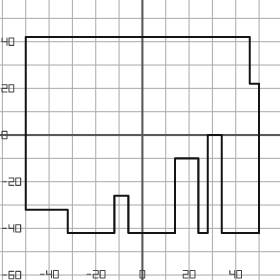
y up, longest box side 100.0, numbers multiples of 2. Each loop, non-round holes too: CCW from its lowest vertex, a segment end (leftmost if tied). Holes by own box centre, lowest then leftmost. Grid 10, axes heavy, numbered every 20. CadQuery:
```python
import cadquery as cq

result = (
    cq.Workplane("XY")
    .moveTo(-32.0, -42.0)
    .lineTo(-12.0, -42.0)
    .lineTo(-12.0, -26.0)
    .lineTo(-6.0, -26.0)
    .lineTo(-6.0, -42.0)
    .lineTo(14.0, -42.0)
    .lineTo(14.0, -10.0)
    .lineTo(24.0, -10.0)
    .lineTo(24.0, -42.0)
    .lineTo(28.0, -42.0)
    .lineTo(28.0, 0.0)
    .lineTo(34.0, 0.0)
    .lineTo(34.0, -42.0)
    .lineTo(50.0, -42.0)
    .lineTo(50.0, 22.0)
    .lineTo(46.0, 22.0)
    .lineTo(46.0, 42.0)
    .lineTo(-50.0, 42.0)
    .lineTo(-50.0, -32.0)
    .lineTo(-32.0, -32.0)
    .close()
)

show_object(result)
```